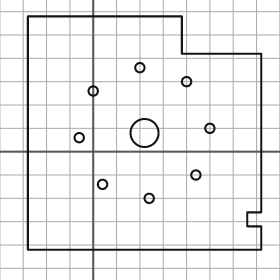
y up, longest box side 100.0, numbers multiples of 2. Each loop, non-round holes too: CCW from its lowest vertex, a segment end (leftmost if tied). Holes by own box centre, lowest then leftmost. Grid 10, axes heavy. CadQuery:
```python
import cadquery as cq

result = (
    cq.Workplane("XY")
    .moveTo(-28.0, -42.0)
    .lineTo(72.0, -42.0)
    .lineTo(72.0, -32.0)
    .lineTo(66.0, -32.0)
    .lineTo(66.0, -26.0)
    .lineTo(72.0, -26.0)
    .lineTo(72.0, 42.0)
    .lineTo(38.0, 42.0)
    .lineTo(38.0, 58.0)
    .lineTo(-28.0, 58.0)
    .close()
    .moveTo(24.0, -20.0)
    .circle(2.0)
    .moveTo(4.0, -14.0)
    .circle(2.0)
    .moveTo(44.0, -10.0)
    .circle(2.0)
    .moveTo(-6.0, 6.0)
    .circle(2.0)
    .moveTo(22.0, 8.0)
    .circle(6.0)
    .moveTo(50.0, 10.0)
    .circle(2.0)
    .moveTo(0.0, 26.0)
    .circle(2.0)
    .moveTo(40.0, 30.0)
    .circle(2.0)
    .moveTo(20.0, 36.0)
    .circle(2.0)
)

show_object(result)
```